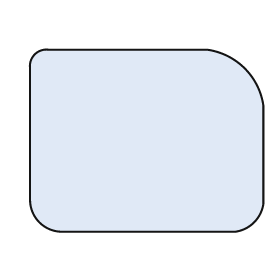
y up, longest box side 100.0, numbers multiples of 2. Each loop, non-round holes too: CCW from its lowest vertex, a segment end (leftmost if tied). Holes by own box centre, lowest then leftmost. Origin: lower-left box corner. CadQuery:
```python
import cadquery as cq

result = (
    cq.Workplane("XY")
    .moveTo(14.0, 0.0)
    .lineTo(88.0, 0.0)
    .threePointArc((96.0, 4.0), (100.0, 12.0))
    .lineTo(100.0, 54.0)
    .threePointArc((92.0, 70.0), (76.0, 78.0))
    .lineTo(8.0, 78.0)
    .threePointArc((2.0, 76.0), (0.0, 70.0))
    .lineTo(0.0, 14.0)
    .threePointArc((4.0, 4.0), (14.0, 0.0))
    .close()
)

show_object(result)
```